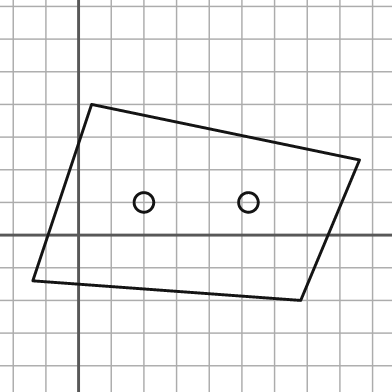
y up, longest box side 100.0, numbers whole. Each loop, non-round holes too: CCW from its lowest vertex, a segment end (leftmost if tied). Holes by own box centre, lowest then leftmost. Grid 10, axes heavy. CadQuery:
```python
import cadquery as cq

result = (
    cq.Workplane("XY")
    .moveTo(68.0, -20.0)
    .lineTo(86.0, 23.0)
    .lineTo(4.0, 40.0)
    .lineTo(-14.0, -14.0)
    .close()
    .moveTo(20.0, 10.0)
    .circle(3.0)
    .moveTo(52.0, 10.0)
    .circle(3.0)
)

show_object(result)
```